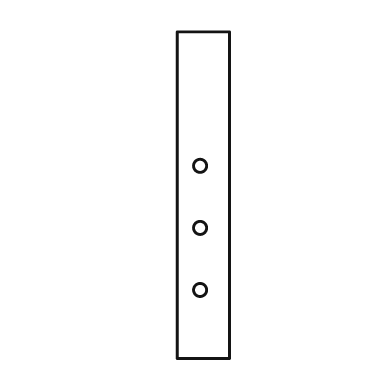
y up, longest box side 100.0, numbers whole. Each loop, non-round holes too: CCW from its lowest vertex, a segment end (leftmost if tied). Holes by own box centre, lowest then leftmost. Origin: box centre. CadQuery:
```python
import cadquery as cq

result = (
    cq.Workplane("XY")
    .moveTo(-8.0, -50.0)
    .lineTo(8.0, -50.0)
    .lineTo(8.0, 50.0)
    .lineTo(-8.0, 50.0)
    .close()
    .moveTo(-1.0, -29.0)
    .circle(2.0)
    .moveTo(-1.0, -10.0)
    .circle(2.0)
    .moveTo(-1.0, 9.0)
    .circle(2.0)
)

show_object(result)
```